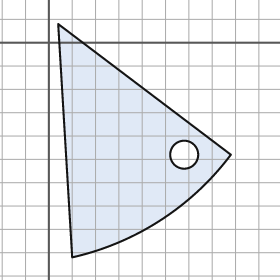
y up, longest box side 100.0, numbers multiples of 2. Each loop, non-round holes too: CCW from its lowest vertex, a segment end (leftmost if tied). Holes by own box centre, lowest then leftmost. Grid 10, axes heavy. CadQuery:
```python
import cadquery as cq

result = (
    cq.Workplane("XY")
    .moveTo(10.0, -92.0)
    .threePointArc((48.0, -76.0), (78.0, -48.0))
    .lineTo(4.0, 8.0)
    .close()
    .moveTo(58.0, -48.0)
    .circle(6.0)
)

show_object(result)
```